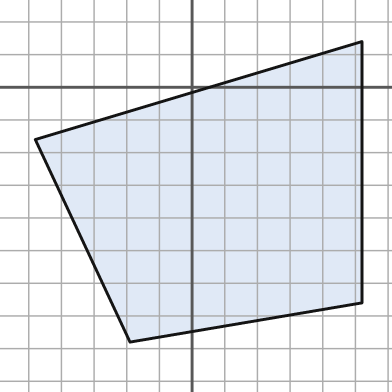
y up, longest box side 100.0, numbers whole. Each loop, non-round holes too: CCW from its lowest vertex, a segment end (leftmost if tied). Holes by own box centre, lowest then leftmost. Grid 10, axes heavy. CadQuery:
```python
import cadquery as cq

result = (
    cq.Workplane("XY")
    .moveTo(-19.0, -78.0)
    .lineTo(52.0, -66.0)
    .lineTo(52.0, 14.0)
    .lineTo(-48.0, -16.0)
    .close()
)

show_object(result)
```